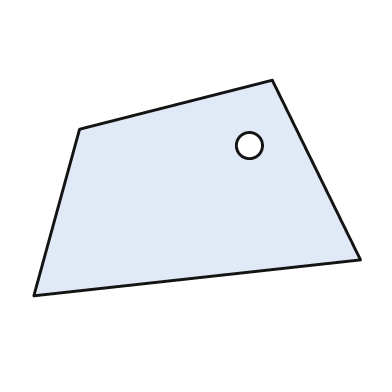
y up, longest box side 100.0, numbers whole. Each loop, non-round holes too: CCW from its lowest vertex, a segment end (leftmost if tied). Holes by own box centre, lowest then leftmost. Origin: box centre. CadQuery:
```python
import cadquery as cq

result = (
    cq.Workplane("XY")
    .moveTo(-50.0, -33.0)
    .lineTo(50.0, -22.0)
    .lineTo(23.0, 33.0)
    .lineTo(-36.0, 18.0)
    .close()
    .moveTo(16.0, 13.0)
    .circle(4.0)
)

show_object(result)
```